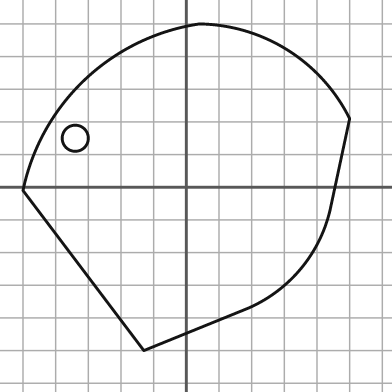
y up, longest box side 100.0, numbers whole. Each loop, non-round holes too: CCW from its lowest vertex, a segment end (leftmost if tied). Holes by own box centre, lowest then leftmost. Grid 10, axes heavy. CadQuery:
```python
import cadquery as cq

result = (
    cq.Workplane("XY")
    .moveTo(-13.0, -50.0)
    .lineTo(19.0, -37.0)
    .threePointArc((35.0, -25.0), (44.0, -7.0))
    .lineTo(50.0, 21.0)
    .threePointArc((31.0, 42.0), (4.0, 50.0))
    .threePointArc((-31.0, 33.0), (-50.0, -1.0))
    .close()
    .moveTo(-34.0, 15.0)
    .circle(4.0)
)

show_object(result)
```